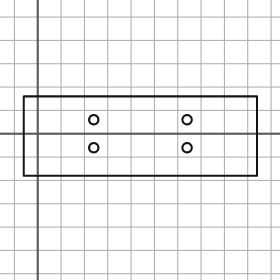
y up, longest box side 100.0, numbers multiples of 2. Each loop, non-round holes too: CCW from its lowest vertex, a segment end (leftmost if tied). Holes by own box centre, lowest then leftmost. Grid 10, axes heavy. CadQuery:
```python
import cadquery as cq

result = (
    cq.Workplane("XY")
    .moveTo(-6.0, -18.0)
    .lineTo(94.0, -18.0)
    .lineTo(94.0, 16.0)
    .lineTo(-6.0, 16.0)
    .close()
    .moveTo(24.0, -6.0)
    .circle(2.0)
    .moveTo(64.0, -6.0)
    .circle(2.0)
    .moveTo(24.0, 6.0)
    .circle(2.0)
    .moveTo(64.0, 6.0)
    .circle(2.0)
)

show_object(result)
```